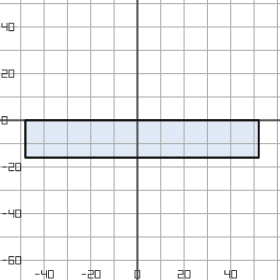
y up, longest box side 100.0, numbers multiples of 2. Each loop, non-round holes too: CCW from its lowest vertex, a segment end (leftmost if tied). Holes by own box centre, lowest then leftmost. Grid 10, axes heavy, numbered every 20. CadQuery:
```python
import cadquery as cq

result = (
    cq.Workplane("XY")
    .moveTo(-48.0, -16.0)
    .lineTo(52.0, -16.0)
    .lineTo(52.0, 0.0)
    .lineTo(-48.0, 0.0)
    .close()
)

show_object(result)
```